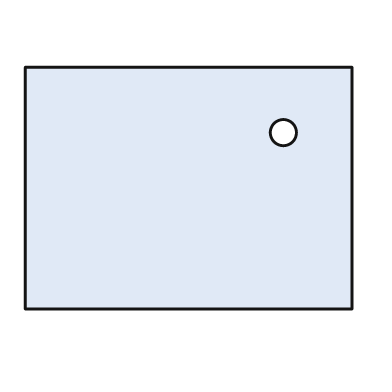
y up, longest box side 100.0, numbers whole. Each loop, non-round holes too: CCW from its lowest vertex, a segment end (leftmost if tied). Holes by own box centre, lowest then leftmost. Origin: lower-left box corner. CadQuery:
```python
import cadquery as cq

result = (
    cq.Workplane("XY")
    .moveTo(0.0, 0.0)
    .lineTo(100.0, 0.0)
    .lineTo(100.0, 74.0)
    .lineTo(0.0, 74.0)
    .close()
    .moveTo(79.0, 54.0)
    .circle(4.0)
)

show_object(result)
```